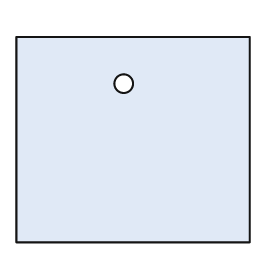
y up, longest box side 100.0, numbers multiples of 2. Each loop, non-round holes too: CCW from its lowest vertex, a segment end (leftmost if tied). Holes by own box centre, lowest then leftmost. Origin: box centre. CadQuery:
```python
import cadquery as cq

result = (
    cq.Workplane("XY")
    .moveTo(-50.0, -44.0)
    .lineTo(50.0, -44.0)
    .lineTo(50.0, 44.0)
    .lineTo(-50.0, 44.0)
    .close()
    .moveTo(-4.0, 24.0)
    .circle(4.0)
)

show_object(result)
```